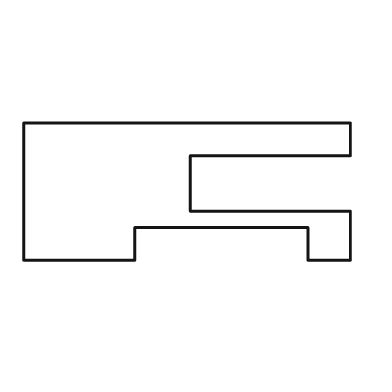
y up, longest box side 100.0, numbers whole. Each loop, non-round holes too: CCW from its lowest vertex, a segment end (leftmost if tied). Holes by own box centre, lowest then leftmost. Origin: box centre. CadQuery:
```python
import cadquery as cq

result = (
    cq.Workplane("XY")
    .moveTo(-50.0, -21.0)
    .lineTo(-16.0, -21.0)
    .lineTo(-16.0, -11.0)
    .lineTo(37.0, -11.0)
    .lineTo(37.0, -21.0)
    .lineTo(50.0, -21.0)
    .lineTo(50.0, -6.0)
    .lineTo(1.0, -6.0)
    .lineTo(1.0, 11.0)
    .lineTo(50.0, 11.0)
    .lineTo(50.0, 21.0)
    .lineTo(-50.0, 21.0)
    .close()
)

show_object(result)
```